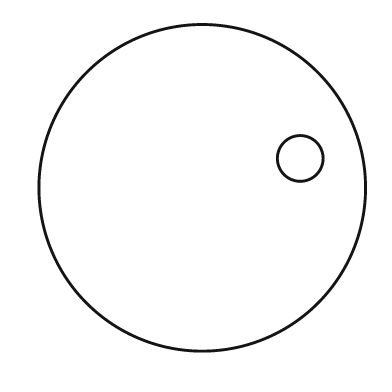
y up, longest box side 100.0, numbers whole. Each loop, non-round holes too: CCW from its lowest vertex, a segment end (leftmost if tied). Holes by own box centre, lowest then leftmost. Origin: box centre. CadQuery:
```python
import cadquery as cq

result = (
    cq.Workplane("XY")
    .moveTo(0.0, 0.0)
    .circle(50.0)
    .moveTo(30.0, 9.0)
    .circle(7.0)
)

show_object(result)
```